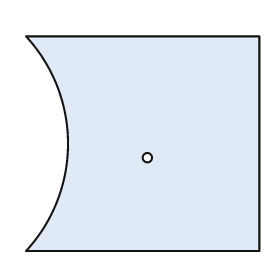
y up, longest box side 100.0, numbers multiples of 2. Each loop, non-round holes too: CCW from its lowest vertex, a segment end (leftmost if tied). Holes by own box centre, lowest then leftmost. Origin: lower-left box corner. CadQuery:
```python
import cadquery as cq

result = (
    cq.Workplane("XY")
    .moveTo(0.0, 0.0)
    .lineTo(100.0, 0.0)
    .lineTo(100.0, 92.0)
    .lineTo(0.0, 92.0)
    .threePointArc((18.0, 46.0), (0.0, 0.0))
    .close()
    .moveTo(52.0, 40.0)
    .circle(2.0)
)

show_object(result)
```